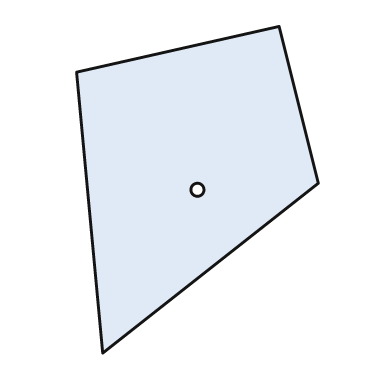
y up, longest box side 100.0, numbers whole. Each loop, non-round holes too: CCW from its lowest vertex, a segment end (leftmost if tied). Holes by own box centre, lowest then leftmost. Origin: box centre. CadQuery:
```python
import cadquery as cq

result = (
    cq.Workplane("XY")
    .moveTo(-29.0, -50.0)
    .lineTo(37.0, 2.0)
    .lineTo(25.0, 50.0)
    .lineTo(-37.0, 36.0)
    .close()
    .moveTo(0.0, 0.0)
    .circle(2.0)
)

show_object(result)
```